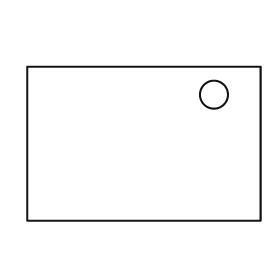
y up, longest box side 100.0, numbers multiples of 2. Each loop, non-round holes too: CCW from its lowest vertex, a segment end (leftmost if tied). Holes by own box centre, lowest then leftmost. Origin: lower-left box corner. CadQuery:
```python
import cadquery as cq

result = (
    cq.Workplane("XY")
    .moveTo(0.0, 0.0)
    .lineTo(100.0, 0.0)
    .lineTo(100.0, 66.0)
    .lineTo(0.0, 66.0)
    .close()
    .moveTo(80.0, 54.0)
    .circle(6.0)
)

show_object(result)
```